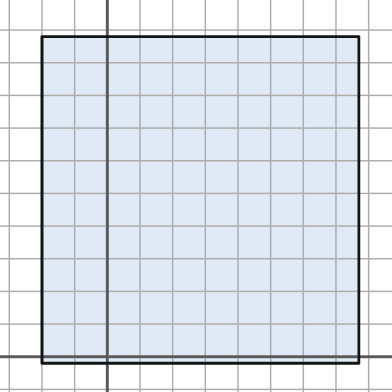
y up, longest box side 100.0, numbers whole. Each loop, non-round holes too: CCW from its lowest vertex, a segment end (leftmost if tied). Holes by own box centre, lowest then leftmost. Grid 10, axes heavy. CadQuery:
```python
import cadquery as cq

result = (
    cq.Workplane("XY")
    .moveTo(-20.0, -2.0)
    .lineTo(77.0, -2.0)
    .lineTo(77.0, 98.0)
    .lineTo(-20.0, 98.0)
    .close()
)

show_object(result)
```